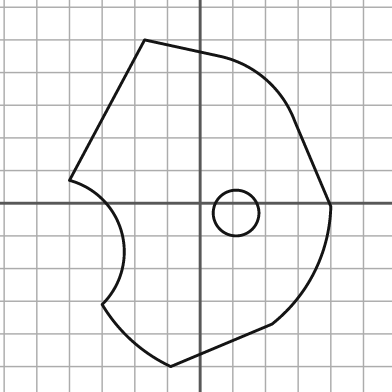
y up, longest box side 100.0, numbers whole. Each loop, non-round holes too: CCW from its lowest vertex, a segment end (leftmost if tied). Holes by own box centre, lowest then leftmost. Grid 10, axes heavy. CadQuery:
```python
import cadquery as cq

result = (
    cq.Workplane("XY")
    .moveTo(-9.0, -50.0)
    .lineTo(22.0, -37.0)
    .threePointArc((35.0, -21.0), (40.0, -1.0))
    .lineTo(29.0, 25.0)
    .threePointArc((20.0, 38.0), (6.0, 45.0))
    .lineTo(-17.0, 50.0)
    .lineTo(-40.0, 7.0)
    .threePointArc((-24.0, -9.0), (-30.0, -31.0))
    .threePointArc((-21.0, -42.0), (-9.0, -50.0))
    .close()
    .moveTo(11.0, -3.0)
    .circle(7.0)
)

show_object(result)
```